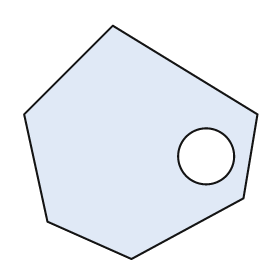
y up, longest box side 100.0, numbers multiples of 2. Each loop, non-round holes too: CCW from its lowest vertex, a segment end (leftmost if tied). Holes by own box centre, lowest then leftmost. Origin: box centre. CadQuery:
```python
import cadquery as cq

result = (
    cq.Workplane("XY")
    .moveTo(-4.0, -50.0)
    .lineTo(44.0, -24.0)
    .lineTo(50.0, 12.0)
    .lineTo(-12.0, 50.0)
    .lineTo(-50.0, 12.0)
    .lineTo(-40.0, -34.0)
    .close()
    .moveTo(28.0, -6.0)
    .circle(12.0)
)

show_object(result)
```